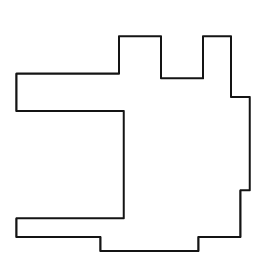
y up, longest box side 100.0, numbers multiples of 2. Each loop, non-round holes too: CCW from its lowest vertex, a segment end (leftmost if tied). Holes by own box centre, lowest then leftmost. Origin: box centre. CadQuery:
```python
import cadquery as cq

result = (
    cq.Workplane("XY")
    .moveTo(-14.0, -46.0)
    .lineTo(28.0, -46.0)
    .lineTo(28.0, -40.0)
    .lineTo(46.0, -40.0)
    .lineTo(46.0, -20.0)
    .lineTo(50.0, -20.0)
    .lineTo(50.0, 20.0)
    .lineTo(42.0, 20.0)
    .lineTo(42.0, 46.0)
    .lineTo(30.0, 46.0)
    .lineTo(30.0, 28.0)
    .lineTo(12.0, 28.0)
    .lineTo(12.0, 46.0)
    .lineTo(-6.0, 46.0)
    .lineTo(-6.0, 30.0)
    .lineTo(-50.0, 30.0)
    .lineTo(-50.0, 14.0)
    .lineTo(-4.0, 14.0)
    .lineTo(-4.0, -32.0)
    .lineTo(-50.0, -32.0)
    .lineTo(-50.0, -40.0)
    .lineTo(-14.0, -40.0)
    .close()
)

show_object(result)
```